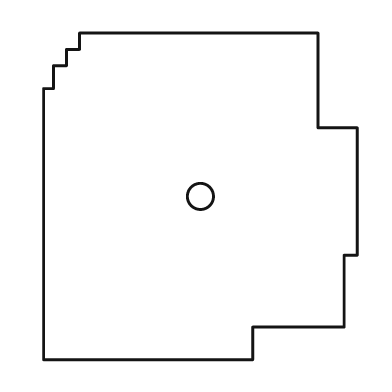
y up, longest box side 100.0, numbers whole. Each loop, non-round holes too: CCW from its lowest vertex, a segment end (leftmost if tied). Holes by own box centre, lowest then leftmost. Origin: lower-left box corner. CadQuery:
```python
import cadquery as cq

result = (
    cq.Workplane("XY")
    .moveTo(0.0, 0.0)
    .lineTo(64.0, 0.0)
    .lineTo(64.0, 10.0)
    .lineTo(92.0, 10.0)
    .lineTo(92.0, 32.0)
    .lineTo(96.0, 32.0)
    .lineTo(96.0, 71.0)
    .lineTo(84.0, 71.0)
    .lineTo(84.0, 100.0)
    .lineTo(11.0, 100.0)
    .lineTo(11.0, 95.0)
    .lineTo(7.0, 95.0)
    .lineTo(7.0, 90.0)
    .lineTo(3.0, 90.0)
    .lineTo(3.0, 83.0)
    .lineTo(0.0, 83.0)
    .close()
    .moveTo(48.0, 50.0)
    .circle(4.0)
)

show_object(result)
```